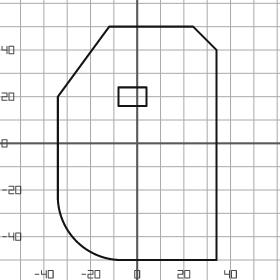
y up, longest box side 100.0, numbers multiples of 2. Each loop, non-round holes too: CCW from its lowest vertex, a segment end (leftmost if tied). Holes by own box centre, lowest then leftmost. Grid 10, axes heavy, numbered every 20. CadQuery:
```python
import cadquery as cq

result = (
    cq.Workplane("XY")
    .moveTo(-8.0, -50.0)
    .lineTo(34.0, -50.0)
    .lineTo(34.0, 40.0)
    .lineTo(24.0, 50.0)
    .lineTo(-12.0, 50.0)
    .lineTo(-34.0, 20.0)
    .lineTo(-34.0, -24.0)
    .threePointArc((-26.0, -42.0), (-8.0, -50.0))
    .close()
    .moveTo(-8.0, 16.0)
    .lineTo(4.0, 16.0)
    .lineTo(4.0, 24.0)
    .lineTo(-8.0, 24.0)
    .close()
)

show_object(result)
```